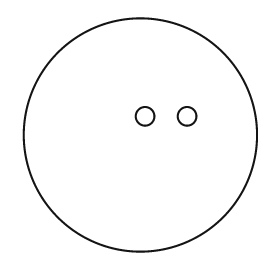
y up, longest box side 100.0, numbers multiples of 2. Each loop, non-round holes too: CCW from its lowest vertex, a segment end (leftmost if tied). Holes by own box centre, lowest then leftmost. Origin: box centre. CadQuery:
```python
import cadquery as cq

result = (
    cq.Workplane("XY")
    .moveTo(0.0, 0.0)
    .circle(50.0)
    .moveTo(2.0, 8.0)
    .circle(4.0)
    .moveTo(20.0, 8.0)
    .circle(4.0)
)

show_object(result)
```